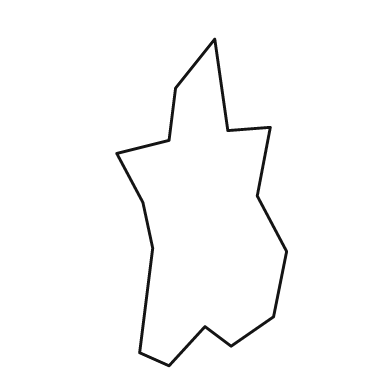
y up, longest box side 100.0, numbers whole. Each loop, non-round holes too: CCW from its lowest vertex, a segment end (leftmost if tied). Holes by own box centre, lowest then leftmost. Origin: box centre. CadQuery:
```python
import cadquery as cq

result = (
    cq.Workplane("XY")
    .moveTo(-10.0, -50.0)
    .lineTo(1.0, -38.0)
    .lineTo(9.0, -44.0)
    .lineTo(22.0, -35.0)
    .lineTo(26.0, -15.0)
    .lineTo(17.0, 2.0)
    .lineTo(21.0, 23.0)
    .lineTo(8.0, 22.0)
    .lineTo(4.0, 50.0)
    .lineTo(-8.0, 35.0)
    .lineTo(-10.0, 19.0)
    .lineTo(-26.0, 15.0)
    .lineTo(-18.0, 0.0)
    .lineTo(-15.0, -14.0)
    .lineTo(-19.0, -46.0)
    .close()
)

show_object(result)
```